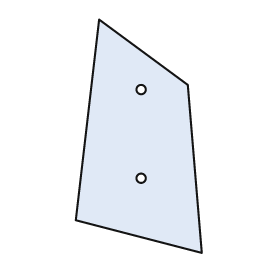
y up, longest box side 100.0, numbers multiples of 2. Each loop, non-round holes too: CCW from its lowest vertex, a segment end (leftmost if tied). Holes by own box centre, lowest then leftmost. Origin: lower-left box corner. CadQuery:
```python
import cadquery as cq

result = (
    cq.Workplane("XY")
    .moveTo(54.0, 0.0)
    .lineTo(48.0, 72.0)
    .lineTo(10.0, 100.0)
    .lineTo(0.0, 14.0)
    .close()
    .moveTo(28.0, 32.0)
    .circle(2.0)
    .moveTo(28.0, 70.0)
    .circle(2.0)
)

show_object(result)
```